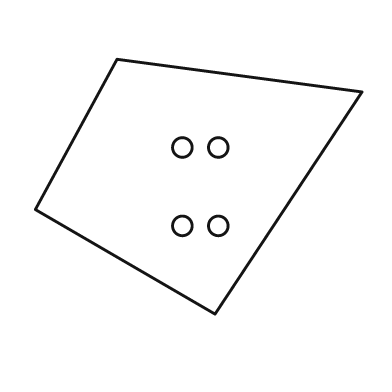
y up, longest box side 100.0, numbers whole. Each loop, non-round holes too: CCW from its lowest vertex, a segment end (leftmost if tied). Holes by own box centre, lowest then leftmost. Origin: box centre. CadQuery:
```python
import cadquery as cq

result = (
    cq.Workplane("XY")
    .moveTo(5.0, -39.0)
    .lineTo(50.0, 29.0)
    .lineTo(-25.0, 39.0)
    .lineTo(-50.0, -7.0)
    .close()
    .moveTo(-5.0, -12.0)
    .circle(3.0)
    .moveTo(6.0, -12.0)
    .circle(3.0)
    .moveTo(-5.0, 12.0)
    .circle(3.0)
    .moveTo(6.0, 12.0)
    .circle(3.0)
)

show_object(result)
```